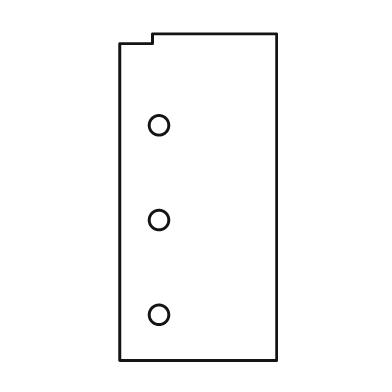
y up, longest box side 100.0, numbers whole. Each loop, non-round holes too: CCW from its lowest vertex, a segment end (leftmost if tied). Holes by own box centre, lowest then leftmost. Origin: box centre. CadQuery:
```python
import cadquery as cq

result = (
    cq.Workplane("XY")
    .moveTo(-24.0, -50.0)
    .lineTo(24.0, -50.0)
    .lineTo(24.0, 50.0)
    .lineTo(-14.0, 50.0)
    .lineTo(-14.0, 47.0)
    .lineTo(-24.0, 47.0)
    .close()
    .moveTo(-12.0, -36.0)
    .circle(3.0)
    .moveTo(-12.0, -7.0)
    .circle(3.0)
    .moveTo(-12.0, 22.0)
    .circle(3.0)
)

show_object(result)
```